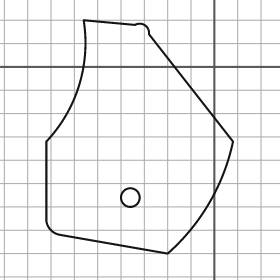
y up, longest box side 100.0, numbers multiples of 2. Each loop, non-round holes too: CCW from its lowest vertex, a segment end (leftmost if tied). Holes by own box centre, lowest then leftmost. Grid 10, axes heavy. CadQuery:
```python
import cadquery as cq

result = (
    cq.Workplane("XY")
    .moveTo(-20.0, -80.0)
    .threePointArc((-2.0, -58.0), (8.0, -32.0))
    .lineTo(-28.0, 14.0)
    .threePointArc((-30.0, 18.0), (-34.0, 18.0))
    .lineTo(-56.0, 20.0)
    .threePointArc((-58.0, -8.0), (-72.0, -32.0))
    .lineTo(-72.0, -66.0)
    .threePointArc((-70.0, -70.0), (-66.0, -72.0))
    .close()
    .moveTo(-36.0, -56.0)
    .circle(4.0)
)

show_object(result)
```